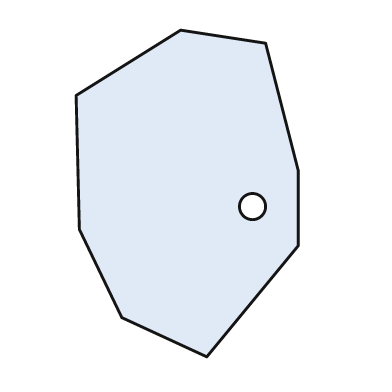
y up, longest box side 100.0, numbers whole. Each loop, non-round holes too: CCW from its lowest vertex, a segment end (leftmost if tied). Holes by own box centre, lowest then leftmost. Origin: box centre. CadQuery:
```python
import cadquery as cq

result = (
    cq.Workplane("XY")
    .moveTo(6.0, -50.0)
    .lineTo(34.0, -16.0)
    .lineTo(34.0, 7.0)
    .lineTo(24.0, 46.0)
    .lineTo(-2.0, 50.0)
    .lineTo(-34.0, 30.0)
    .lineTo(-33.0, -11.0)
    .lineTo(-20.0, -38.0)
    .close()
    .moveTo(20.0, -4.0)
    .circle(4.0)
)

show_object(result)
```